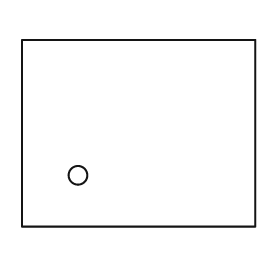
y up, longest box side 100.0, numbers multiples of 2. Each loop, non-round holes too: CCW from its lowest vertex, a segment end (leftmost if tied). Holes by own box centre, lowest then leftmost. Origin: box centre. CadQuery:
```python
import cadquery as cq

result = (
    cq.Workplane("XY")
    .moveTo(-50.0, -40.0)
    .lineTo(50.0, -40.0)
    .lineTo(50.0, 40.0)
    .lineTo(-50.0, 40.0)
    .close()
    .moveTo(-26.0, -18.0)
    .circle(4.0)
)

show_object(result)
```